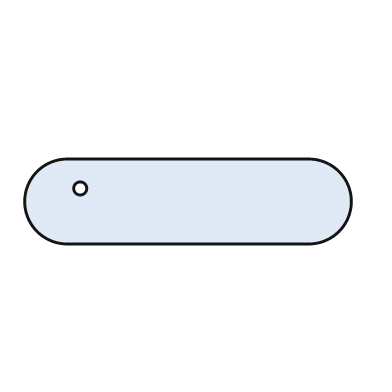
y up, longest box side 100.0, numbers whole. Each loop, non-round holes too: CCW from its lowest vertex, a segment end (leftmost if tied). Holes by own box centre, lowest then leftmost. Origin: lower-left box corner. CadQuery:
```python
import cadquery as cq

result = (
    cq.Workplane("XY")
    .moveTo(13.0, 0.0)
    .lineTo(87.0, 0.0)
    .threePointArc((100.0, 13.0), (87.0, 26.0))
    .lineTo(13.0, 26.0)
    .threePointArc((0.0, 13.0), (13.0, 0.0))
    .close()
    .moveTo(17.0, 17.0)
    .circle(2.0)
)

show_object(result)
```